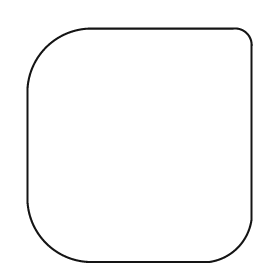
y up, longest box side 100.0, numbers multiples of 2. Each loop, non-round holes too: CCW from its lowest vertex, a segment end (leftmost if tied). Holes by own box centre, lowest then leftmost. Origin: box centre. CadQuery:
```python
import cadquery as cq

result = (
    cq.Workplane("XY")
    .moveTo(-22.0, -50.0)
    .lineTo(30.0, -50.0)
    .threePointArc((42.0, -44.0), (48.0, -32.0))
    .lineTo(48.0, 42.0)
    .threePointArc((46.0, 48.0), (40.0, 50.0))
    .lineTo(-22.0, 50.0)
    .threePointArc((-40.0, 42.0), (-48.0, 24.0))
    .lineTo(-48.0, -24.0)
    .threePointArc((-40.0, -42.0), (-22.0, -50.0))
    .close()
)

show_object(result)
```